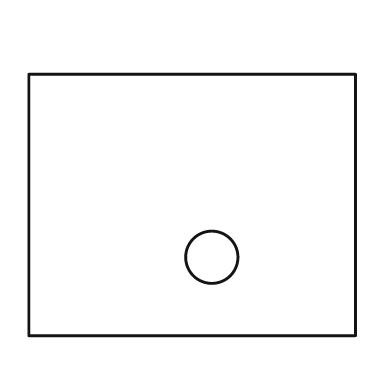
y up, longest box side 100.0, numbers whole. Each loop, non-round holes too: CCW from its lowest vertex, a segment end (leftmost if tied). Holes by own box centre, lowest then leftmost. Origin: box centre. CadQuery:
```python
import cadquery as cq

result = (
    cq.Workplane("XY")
    .moveTo(-50.0, -40.0)
    .lineTo(50.0, -40.0)
    .lineTo(50.0, 40.0)
    .lineTo(-50.0, 40.0)
    .close()
    .moveTo(6.0, -16.0)
    .circle(8.0)
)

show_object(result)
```